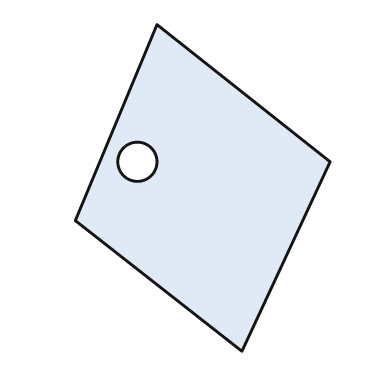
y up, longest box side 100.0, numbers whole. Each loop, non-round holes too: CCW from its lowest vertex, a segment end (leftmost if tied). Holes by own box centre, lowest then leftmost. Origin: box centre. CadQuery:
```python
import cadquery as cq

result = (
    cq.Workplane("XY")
    .moveTo(12.0, -50.0)
    .lineTo(39.0, 8.0)
    .lineTo(-14.0, 50.0)
    .lineTo(-39.0, -10.0)
    .close()
    .moveTo(-20.0, 8.0)
    .circle(6.0)
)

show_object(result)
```